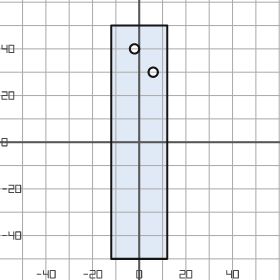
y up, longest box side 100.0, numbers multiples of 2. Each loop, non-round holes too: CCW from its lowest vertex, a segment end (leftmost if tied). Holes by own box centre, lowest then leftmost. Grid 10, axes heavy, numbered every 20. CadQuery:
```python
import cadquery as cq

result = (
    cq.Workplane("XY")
    .moveTo(-12.0, -50.0)
    .lineTo(12.0, -50.0)
    .lineTo(12.0, 50.0)
    .lineTo(-12.0, 50.0)
    .close()
    .moveTo(6.0, 30.0)
    .circle(2.0)
    .moveTo(-2.0, 40.0)
    .circle(2.0)
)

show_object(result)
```